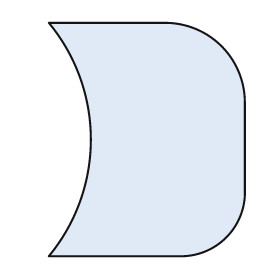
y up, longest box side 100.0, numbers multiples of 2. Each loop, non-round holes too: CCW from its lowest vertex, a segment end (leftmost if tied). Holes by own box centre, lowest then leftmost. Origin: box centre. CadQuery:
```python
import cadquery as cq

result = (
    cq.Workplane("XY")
    .moveTo(-42.0, -50.0)
    .lineTo(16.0, -50.0)
    .threePointArc((34.0, -42.0), (42.0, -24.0))
    .lineTo(42.0, 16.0)
    .threePointArc((32.0, 40.0), (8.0, 50.0))
    .lineTo(-42.0, 50.0)
    .threePointArc((-24.0, 0.0), (-42.0, -50.0))
    .close()
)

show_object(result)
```